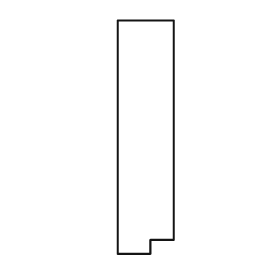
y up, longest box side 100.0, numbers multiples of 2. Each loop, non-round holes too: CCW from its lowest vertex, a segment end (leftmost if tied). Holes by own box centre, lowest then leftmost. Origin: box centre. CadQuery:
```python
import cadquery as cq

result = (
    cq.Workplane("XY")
    .moveTo(-12.0, -50.0)
    .lineTo(2.0, -50.0)
    .lineTo(2.0, -44.0)
    .lineTo(12.0, -44.0)
    .lineTo(12.0, 50.0)
    .lineTo(-12.0, 50.0)
    .close()
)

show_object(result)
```